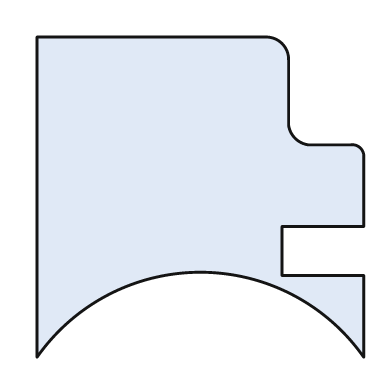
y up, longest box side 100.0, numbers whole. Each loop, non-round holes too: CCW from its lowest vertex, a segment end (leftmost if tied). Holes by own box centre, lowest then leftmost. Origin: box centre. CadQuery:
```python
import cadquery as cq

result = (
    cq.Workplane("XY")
    .moveTo(-50.0, -49.0)
    .threePointArc((0.0, -23.0), (50.0, -49.0))
    .lineTo(50.0, -24.0)
    .lineTo(25.0, -24.0)
    .lineTo(25.0, -9.0)
    .lineTo(50.0, -9.0)
    .lineTo(50.0, 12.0)
    .threePointArc((49.0, 15.0), (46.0, 16.0))
    .lineTo(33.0, 16.0)
    .threePointArc((29.0, 18.0), (27.0, 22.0))
    .lineTo(27.0, 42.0)
    .threePointArc((25.0, 47.0), (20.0, 49.0))
    .lineTo(-50.0, 49.0)
    .close()
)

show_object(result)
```